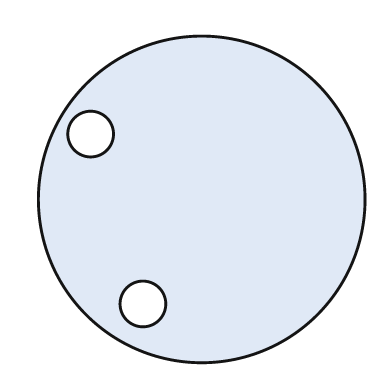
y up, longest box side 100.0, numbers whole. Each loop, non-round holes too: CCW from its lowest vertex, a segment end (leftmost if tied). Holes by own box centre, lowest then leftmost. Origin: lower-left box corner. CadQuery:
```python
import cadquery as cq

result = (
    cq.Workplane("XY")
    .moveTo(50.0, 50.0)
    .circle(50.0)
    .moveTo(32.0, 18.0)
    .circle(7.0)
    .moveTo(16.0, 70.0)
    .circle(7.0)
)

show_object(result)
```